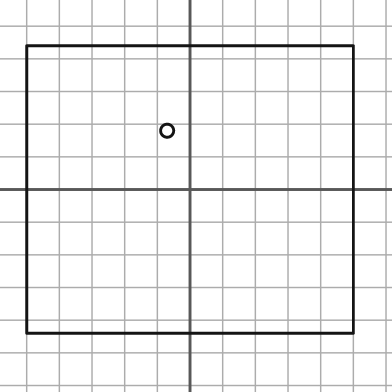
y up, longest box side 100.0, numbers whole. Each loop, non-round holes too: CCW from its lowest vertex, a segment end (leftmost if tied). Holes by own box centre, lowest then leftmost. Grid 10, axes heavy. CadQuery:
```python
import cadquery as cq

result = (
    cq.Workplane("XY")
    .moveTo(-50.0, -44.0)
    .lineTo(50.0, -44.0)
    .lineTo(50.0, 44.0)
    .lineTo(-50.0, 44.0)
    .close()
    .moveTo(-7.0, 18.0)
    .circle(2.0)
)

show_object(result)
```